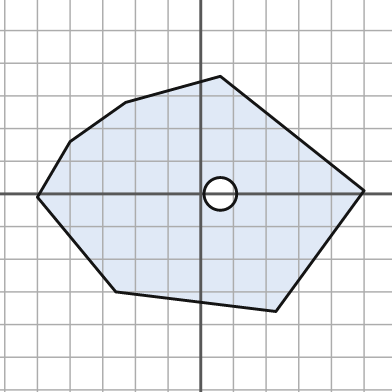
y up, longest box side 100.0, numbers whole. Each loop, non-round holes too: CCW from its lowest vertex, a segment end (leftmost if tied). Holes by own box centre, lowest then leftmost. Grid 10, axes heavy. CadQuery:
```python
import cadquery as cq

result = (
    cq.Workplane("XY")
    .moveTo(23.0, -36.0)
    .lineTo(50.0, 1.0)
    .lineTo(6.0, 36.0)
    .lineTo(-23.0, 28.0)
    .lineTo(-40.0, 16.0)
    .lineTo(-50.0, -1.0)
    .lineTo(-26.0, -30.0)
    .close()
    .moveTo(6.0, 0.0)
    .circle(5.0)
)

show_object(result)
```